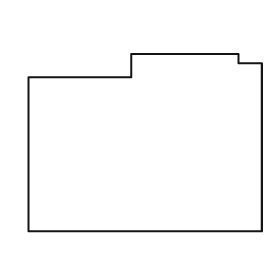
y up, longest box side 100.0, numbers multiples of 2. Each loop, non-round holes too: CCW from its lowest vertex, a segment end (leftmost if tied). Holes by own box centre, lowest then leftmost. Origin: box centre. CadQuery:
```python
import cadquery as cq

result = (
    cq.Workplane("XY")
    .moveTo(-50.0, -38.0)
    .lineTo(50.0, -38.0)
    .lineTo(50.0, 34.0)
    .lineTo(40.0, 34.0)
    .lineTo(40.0, 38.0)
    .lineTo(-6.0, 38.0)
    .lineTo(-6.0, 28.0)
    .lineTo(-50.0, 28.0)
    .close()
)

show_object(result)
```